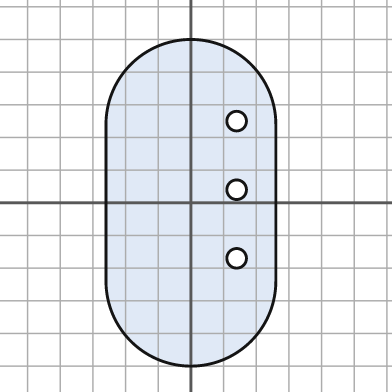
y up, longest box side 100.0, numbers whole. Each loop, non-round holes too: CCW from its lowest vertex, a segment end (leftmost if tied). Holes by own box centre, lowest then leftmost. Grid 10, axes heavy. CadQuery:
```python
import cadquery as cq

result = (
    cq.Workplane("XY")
    .moveTo(-26.0, -24.0)
    .threePointArc((0.0, -50.0), (26.0, -24.0))
    .lineTo(26.0, 24.0)
    .threePointArc((0.0, 50.0), (-26.0, 24.0))
    .close()
    .moveTo(14.0, -17.0)
    .circle(3.0)
    .moveTo(14.0, 4.0)
    .circle(3.0)
    .moveTo(14.0, 25.0)
    .circle(3.0)
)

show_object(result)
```